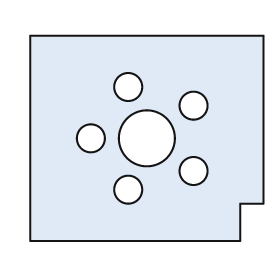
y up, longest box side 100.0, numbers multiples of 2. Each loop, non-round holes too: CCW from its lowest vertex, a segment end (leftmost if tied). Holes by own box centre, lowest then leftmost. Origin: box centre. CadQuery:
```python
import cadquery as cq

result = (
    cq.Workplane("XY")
    .moveTo(-50.0, -44.0)
    .lineTo(40.0, -44.0)
    .lineTo(40.0, -28.0)
    .lineTo(50.0, -28.0)
    .lineTo(50.0, 44.0)
    .lineTo(-50.0, 44.0)
    .close()
    .moveTo(-8.0, -22.0)
    .circle(6.0)
    .moveTo(20.0, -14.0)
    .circle(6.0)
    .moveTo(-24.0, 0.0)
    .circle(6.0)
    .moveTo(0.0, 0.0)
    .circle(12.0)
    .moveTo(20.0, 14.0)
    .circle(6.0)
    .moveTo(-8.0, 22.0)
    .circle(6.0)
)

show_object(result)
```